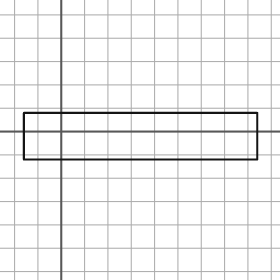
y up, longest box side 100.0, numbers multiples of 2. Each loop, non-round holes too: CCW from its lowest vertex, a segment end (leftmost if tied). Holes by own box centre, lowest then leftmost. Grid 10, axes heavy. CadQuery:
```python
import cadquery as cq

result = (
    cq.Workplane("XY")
    .moveTo(-16.0, -12.0)
    .lineTo(84.0, -12.0)
    .lineTo(84.0, 8.0)
    .lineTo(-16.0, 8.0)
    .close()
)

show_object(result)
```